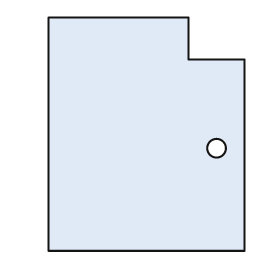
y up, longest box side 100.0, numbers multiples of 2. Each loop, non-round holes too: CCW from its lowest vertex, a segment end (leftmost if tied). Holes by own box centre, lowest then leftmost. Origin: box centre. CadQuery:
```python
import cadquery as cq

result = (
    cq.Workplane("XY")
    .moveTo(-42.0, -50.0)
    .lineTo(42.0, -50.0)
    .lineTo(42.0, 32.0)
    .lineTo(18.0, 32.0)
    .lineTo(18.0, 50.0)
    .lineTo(-42.0, 50.0)
    .close()
    .moveTo(30.0, -6.0)
    .circle(4.0)
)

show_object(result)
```